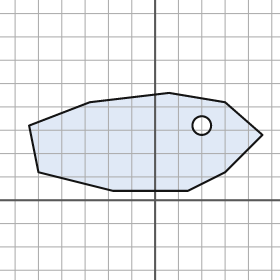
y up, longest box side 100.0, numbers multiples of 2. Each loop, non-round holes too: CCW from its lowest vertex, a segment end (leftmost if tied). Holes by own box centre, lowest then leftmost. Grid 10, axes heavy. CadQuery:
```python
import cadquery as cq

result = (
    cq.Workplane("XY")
    .moveTo(-18.0, 4.0)
    .lineTo(14.0, 4.0)
    .lineTo(30.0, 12.0)
    .lineTo(46.0, 28.0)
    .lineTo(30.0, 42.0)
    .lineTo(6.0, 46.0)
    .lineTo(-28.0, 42.0)
    .lineTo(-54.0, 32.0)
    .lineTo(-50.0, 12.0)
    .close()
    .moveTo(20.0, 32.0)
    .circle(4.0)
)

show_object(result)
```